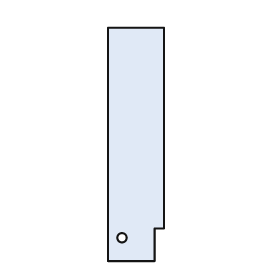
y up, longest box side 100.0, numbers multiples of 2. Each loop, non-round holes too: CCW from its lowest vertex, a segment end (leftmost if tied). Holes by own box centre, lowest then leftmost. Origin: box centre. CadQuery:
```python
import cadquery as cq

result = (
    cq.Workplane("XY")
    .moveTo(-12.0, -50.0)
    .lineTo(8.0, -50.0)
    .lineTo(8.0, -36.0)
    .lineTo(12.0, -36.0)
    .lineTo(12.0, 50.0)
    .lineTo(-12.0, 50.0)
    .close()
    .moveTo(-6.0, -40.0)
    .circle(2.0)
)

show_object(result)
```